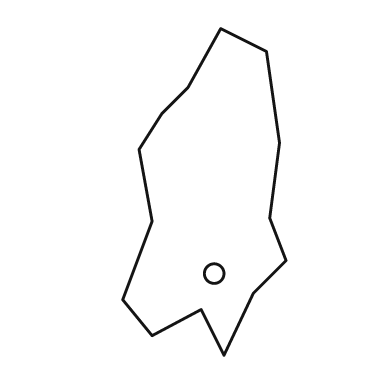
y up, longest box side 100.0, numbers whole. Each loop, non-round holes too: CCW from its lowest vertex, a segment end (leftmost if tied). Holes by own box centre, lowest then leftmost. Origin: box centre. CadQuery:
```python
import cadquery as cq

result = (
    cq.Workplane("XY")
    .moveTo(6.0, -50.0)
    .lineTo(15.0, -31.0)
    .lineTo(25.0, -21.0)
    .lineTo(20.0, -8.0)
    .lineTo(23.0, 15.0)
    .lineTo(19.0, 43.0)
    .lineTo(5.0, 50.0)
    .lineTo(-5.0, 32.0)
    .lineTo(-13.0, 24.0)
    .lineTo(-20.0, 13.0)
    .lineTo(-16.0, -9.0)
    .lineTo(-25.0, -33.0)
    .lineTo(-16.0, -44.0)
    .lineTo(-1.0, -36.0)
    .close()
    .moveTo(3.0, -25.0)
    .circle(3.0)
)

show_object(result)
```